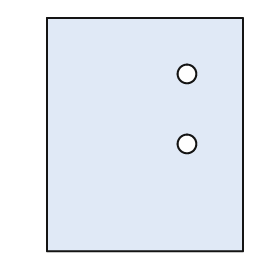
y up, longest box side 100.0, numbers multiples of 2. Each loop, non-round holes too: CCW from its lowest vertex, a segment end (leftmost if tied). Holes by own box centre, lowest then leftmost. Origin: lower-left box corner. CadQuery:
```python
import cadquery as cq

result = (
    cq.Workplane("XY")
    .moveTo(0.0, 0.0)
    .lineTo(84.0, 0.0)
    .lineTo(84.0, 100.0)
    .lineTo(0.0, 100.0)
    .close()
    .moveTo(60.0, 46.0)
    .circle(4.0)
    .moveTo(60.0, 76.0)
    .circle(4.0)
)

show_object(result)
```